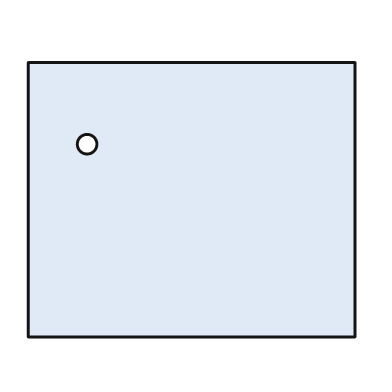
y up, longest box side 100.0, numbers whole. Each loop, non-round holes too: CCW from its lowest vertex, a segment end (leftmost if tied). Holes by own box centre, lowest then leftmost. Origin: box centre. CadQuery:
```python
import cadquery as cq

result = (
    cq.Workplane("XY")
    .moveTo(-50.0, -42.0)
    .lineTo(50.0, -42.0)
    .lineTo(50.0, 42.0)
    .lineTo(-50.0, 42.0)
    .close()
    .moveTo(-32.0, 17.0)
    .circle(3.0)
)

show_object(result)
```